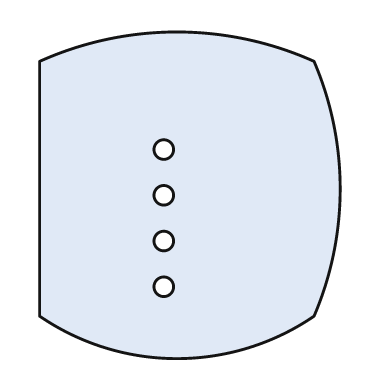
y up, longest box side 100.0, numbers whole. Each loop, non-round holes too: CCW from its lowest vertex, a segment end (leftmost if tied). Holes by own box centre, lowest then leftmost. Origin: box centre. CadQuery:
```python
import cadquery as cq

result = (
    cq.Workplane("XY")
    .moveTo(-46.0, -37.0)
    .threePointArc((-4.0, -50.0), (38.0, -37.0))
    .threePointArc((46.0, 2.0), (38.0, 41.0))
    .threePointArc((-4.0, 50.0), (-46.0, 41.0))
    .close()
    .moveTo(-8.0, -28.0)
    .circle(3.0)
    .moveTo(-8.0, -14.0)
    .circle(3.0)
    .moveTo(-8.0, 0.0)
    .circle(3.0)
    .moveTo(-8.0, 14.0)
    .circle(3.0)
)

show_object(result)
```